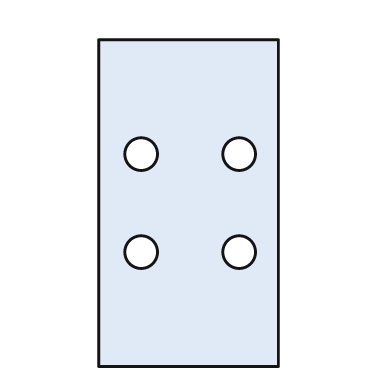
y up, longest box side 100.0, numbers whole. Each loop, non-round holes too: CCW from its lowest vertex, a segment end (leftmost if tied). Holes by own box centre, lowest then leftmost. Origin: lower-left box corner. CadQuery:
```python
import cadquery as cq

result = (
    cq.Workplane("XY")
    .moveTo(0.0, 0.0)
    .lineTo(55.0, 0.0)
    .lineTo(55.0, 100.0)
    .lineTo(0.0, 100.0)
    .close()
    .moveTo(13.0, 35.0)
    .circle(5.0)
    .moveTo(43.0, 35.0)
    .circle(5.0)
    .moveTo(13.0, 65.0)
    .circle(5.0)
    .moveTo(43.0, 65.0)
    .circle(5.0)
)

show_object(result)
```